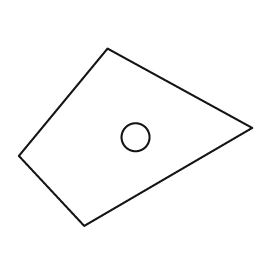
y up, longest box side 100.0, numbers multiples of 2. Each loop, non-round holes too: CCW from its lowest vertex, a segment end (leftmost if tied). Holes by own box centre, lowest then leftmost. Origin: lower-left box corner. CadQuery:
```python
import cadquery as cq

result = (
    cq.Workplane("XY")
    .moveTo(28.0, 0.0)
    .lineTo(100.0, 42.0)
    .lineTo(38.0, 76.0)
    .lineTo(0.0, 30.0)
    .close()
    .moveTo(50.0, 38.0)
    .circle(6.0)
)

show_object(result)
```